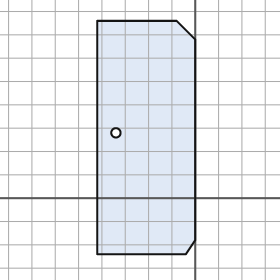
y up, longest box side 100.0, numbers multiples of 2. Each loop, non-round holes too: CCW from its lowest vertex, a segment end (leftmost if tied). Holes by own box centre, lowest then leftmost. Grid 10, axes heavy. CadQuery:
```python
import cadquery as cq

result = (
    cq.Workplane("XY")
    .moveTo(-42.0, -24.0)
    .lineTo(-4.0, -24.0)
    .lineTo(0.0, -18.0)
    .lineTo(0.0, 68.0)
    .lineTo(-8.0, 76.0)
    .lineTo(-42.0, 76.0)
    .close()
    .moveTo(-34.0, 28.0)
    .circle(2.0)
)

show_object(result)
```